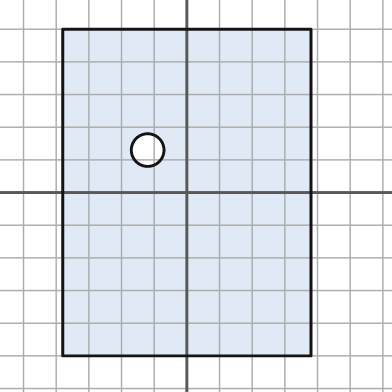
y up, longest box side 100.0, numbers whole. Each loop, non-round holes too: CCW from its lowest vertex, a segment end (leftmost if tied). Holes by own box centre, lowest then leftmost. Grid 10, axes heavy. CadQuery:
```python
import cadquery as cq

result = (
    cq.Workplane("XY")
    .moveTo(-38.0, -50.0)
    .lineTo(38.0, -50.0)
    .lineTo(38.0, 50.0)
    .lineTo(-38.0, 50.0)
    .close()
    .moveTo(-12.0, 13.0)
    .circle(5.0)
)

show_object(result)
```